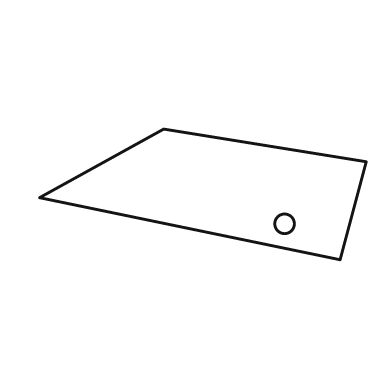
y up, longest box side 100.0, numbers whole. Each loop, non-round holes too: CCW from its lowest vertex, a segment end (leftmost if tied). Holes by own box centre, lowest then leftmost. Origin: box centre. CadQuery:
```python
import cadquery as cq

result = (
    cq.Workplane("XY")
    .moveTo(42.0, -20.0)
    .lineTo(50.0, 10.0)
    .lineTo(-12.0, 20.0)
    .lineTo(-50.0, -1.0)
    .close()
    .moveTo(25.0, -9.0)
    .circle(3.0)
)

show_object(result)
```